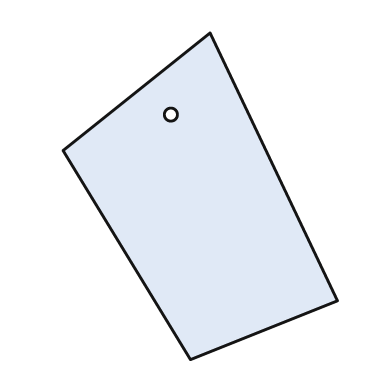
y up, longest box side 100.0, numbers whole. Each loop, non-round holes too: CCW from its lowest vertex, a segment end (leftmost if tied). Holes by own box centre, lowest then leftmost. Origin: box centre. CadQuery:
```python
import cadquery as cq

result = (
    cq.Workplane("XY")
    .moveTo(-3.0, -50.0)
    .lineTo(42.0, -32.0)
    .lineTo(3.0, 50.0)
    .lineTo(-42.0, 14.0)
    .close()
    .moveTo(-9.0, 25.0)
    .circle(2.0)
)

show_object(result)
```